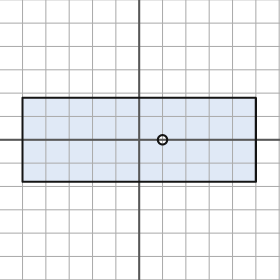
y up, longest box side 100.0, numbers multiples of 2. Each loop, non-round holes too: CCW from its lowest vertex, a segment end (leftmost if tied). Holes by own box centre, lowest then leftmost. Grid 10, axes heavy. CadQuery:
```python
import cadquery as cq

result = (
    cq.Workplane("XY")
    .moveTo(-50.0, -18.0)
    .lineTo(50.0, -18.0)
    .lineTo(50.0, 18.0)
    .lineTo(-50.0, 18.0)
    .close()
    .moveTo(10.0, 0.0)
    .circle(2.0)
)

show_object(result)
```